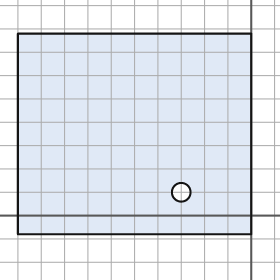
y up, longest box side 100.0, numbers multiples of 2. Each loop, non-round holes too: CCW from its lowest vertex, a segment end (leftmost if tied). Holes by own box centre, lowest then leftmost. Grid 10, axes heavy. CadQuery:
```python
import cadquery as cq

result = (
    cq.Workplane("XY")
    .moveTo(-100.0, -8.0)
    .lineTo(0.0, -8.0)
    .lineTo(0.0, 78.0)
    .lineTo(-100.0, 78.0)
    .close()
    .moveTo(-30.0, 10.0)
    .circle(4.0)
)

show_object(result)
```